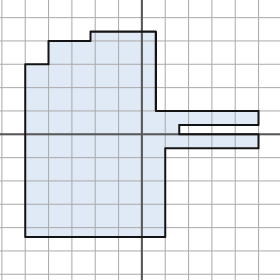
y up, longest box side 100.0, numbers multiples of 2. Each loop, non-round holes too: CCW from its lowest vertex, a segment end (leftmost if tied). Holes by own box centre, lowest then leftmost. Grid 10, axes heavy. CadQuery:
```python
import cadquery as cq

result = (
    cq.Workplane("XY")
    .moveTo(-50.0, -44.0)
    .lineTo(10.0, -44.0)
    .lineTo(10.0, -6.0)
    .lineTo(50.0, -6.0)
    .lineTo(50.0, 0.0)
    .lineTo(16.0, 0.0)
    .lineTo(16.0, 4.0)
    .lineTo(50.0, 4.0)
    .lineTo(50.0, 10.0)
    .lineTo(6.0, 10.0)
    .lineTo(6.0, 44.0)
    .lineTo(-22.0, 44.0)
    .lineTo(-22.0, 40.0)
    .lineTo(-40.0, 40.0)
    .lineTo(-40.0, 30.0)
    .lineTo(-50.0, 30.0)
    .close()
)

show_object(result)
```